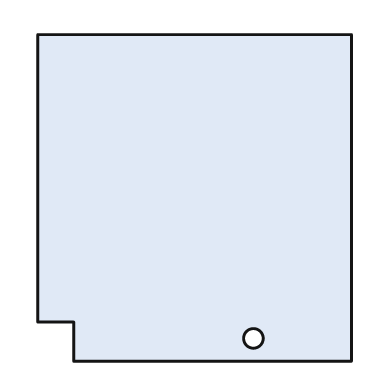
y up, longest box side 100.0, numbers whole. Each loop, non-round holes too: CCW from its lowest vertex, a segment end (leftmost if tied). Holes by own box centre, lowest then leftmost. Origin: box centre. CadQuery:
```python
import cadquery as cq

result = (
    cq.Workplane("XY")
    .moveTo(-37.0, -50.0)
    .lineTo(48.0, -50.0)
    .lineTo(48.0, 50.0)
    .lineTo(-48.0, 50.0)
    .lineTo(-48.0, -38.0)
    .lineTo(-37.0, -38.0)
    .close()
    .moveTo(18.0, -43.0)
    .circle(3.0)
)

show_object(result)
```